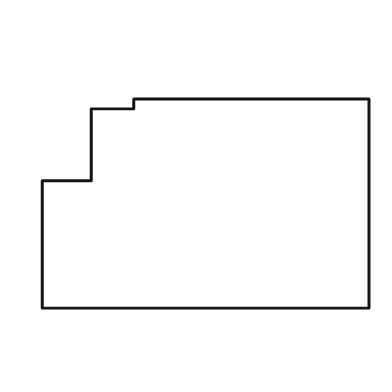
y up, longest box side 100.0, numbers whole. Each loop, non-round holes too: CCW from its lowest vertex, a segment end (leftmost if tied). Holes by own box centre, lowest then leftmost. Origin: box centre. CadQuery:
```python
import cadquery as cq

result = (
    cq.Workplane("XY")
    .moveTo(-50.0, -32.0)
    .lineTo(50.0, -32.0)
    .lineTo(50.0, 32.0)
    .lineTo(-22.0, 32.0)
    .lineTo(-22.0, 29.0)
    .lineTo(-35.0, 29.0)
    .lineTo(-35.0, 7.0)
    .lineTo(-50.0, 7.0)
    .close()
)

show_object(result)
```